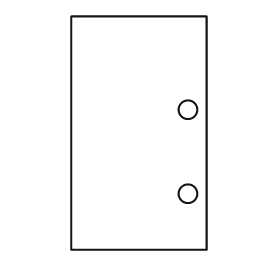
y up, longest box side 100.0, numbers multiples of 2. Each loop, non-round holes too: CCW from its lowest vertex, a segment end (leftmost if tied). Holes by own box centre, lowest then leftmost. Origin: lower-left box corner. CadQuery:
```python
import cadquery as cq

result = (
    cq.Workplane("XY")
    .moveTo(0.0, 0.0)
    .lineTo(58.0, 0.0)
    .lineTo(58.0, 100.0)
    .lineTo(0.0, 100.0)
    .close()
    .moveTo(50.0, 24.0)
    .circle(4.0)
    .moveTo(50.0, 60.0)
    .circle(4.0)
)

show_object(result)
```